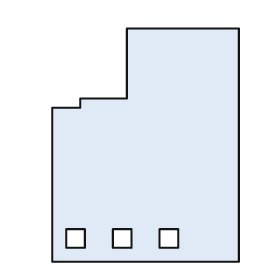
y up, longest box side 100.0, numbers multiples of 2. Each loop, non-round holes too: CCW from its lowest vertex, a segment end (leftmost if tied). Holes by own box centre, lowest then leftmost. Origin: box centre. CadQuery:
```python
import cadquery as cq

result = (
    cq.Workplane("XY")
    .moveTo(-40.0, -50.0)
    .lineTo(40.0, -50.0)
    .lineTo(40.0, 50.0)
    .lineTo(-8.0, 50.0)
    .lineTo(-8.0, 20.0)
    .lineTo(-28.0, 20.0)
    .lineTo(-28.0, 16.0)
    .lineTo(-40.0, 16.0)
    .close()
    .moveTo(-34.0, -44.0)
    .lineTo(-26.0, -44.0)
    .lineTo(-26.0, -36.0)
    .lineTo(-34.0, -36.0)
    .close()
    .moveTo(-14.0, -44.0)
    .lineTo(-6.0, -44.0)
    .lineTo(-6.0, -36.0)
    .lineTo(-14.0, -36.0)
    .close()
    .moveTo(6.0, -44.0)
    .lineTo(14.0, -44.0)
    .lineTo(14.0, -36.0)
    .lineTo(6.0, -36.0)
    .close()
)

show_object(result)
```